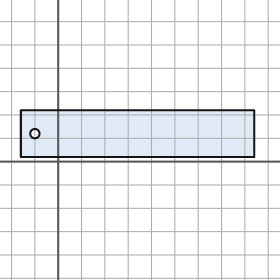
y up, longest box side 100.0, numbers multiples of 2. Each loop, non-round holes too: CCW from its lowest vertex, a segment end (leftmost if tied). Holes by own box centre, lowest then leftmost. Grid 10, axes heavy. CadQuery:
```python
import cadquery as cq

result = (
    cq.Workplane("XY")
    .moveTo(-16.0, 2.0)
    .lineTo(84.0, 2.0)
    .lineTo(84.0, 22.0)
    .lineTo(-16.0, 22.0)
    .close()
    .moveTo(-10.0, 12.0)
    .circle(2.0)
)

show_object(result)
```